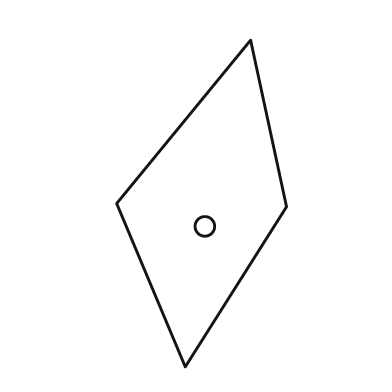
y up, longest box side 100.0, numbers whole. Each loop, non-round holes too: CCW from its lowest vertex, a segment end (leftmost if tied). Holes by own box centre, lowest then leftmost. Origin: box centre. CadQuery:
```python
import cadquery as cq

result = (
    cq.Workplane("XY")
    .moveTo(-5.0, -50.0)
    .lineTo(26.0, -1.0)
    .lineTo(15.0, 50.0)
    .lineTo(-26.0, 0.0)
    .close()
    .moveTo(1.0, -7.0)
    .circle(3.0)
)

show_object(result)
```